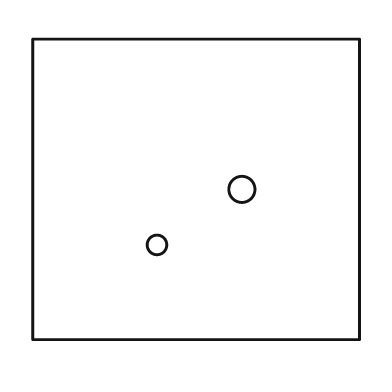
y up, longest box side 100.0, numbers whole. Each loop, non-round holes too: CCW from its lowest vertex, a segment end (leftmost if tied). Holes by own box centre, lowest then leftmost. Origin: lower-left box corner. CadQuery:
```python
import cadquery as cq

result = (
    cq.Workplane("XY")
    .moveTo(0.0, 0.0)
    .lineTo(100.0, 0.0)
    .lineTo(100.0, 92.0)
    .lineTo(0.0, 92.0)
    .close()
    .moveTo(38.0, 29.0)
    .circle(3.0)
    .moveTo(64.0, 46.0)
    .circle(4.0)
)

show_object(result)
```